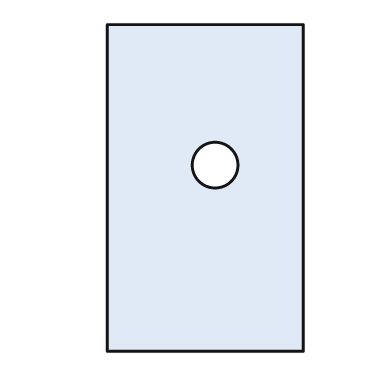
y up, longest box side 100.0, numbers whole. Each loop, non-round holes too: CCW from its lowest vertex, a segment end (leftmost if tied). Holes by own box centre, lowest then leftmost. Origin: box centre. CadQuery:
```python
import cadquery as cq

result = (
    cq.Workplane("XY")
    .moveTo(-30.0, -50.0)
    .lineTo(30.0, -50.0)
    .lineTo(30.0, 50.0)
    .lineTo(-30.0, 50.0)
    .close()
    .moveTo(3.0, 7.0)
    .circle(7.0)
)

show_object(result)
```